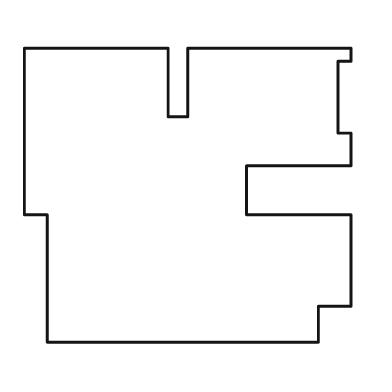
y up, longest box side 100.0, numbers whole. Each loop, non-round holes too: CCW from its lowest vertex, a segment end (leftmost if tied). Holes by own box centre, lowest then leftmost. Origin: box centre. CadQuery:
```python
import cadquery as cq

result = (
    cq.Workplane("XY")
    .moveTo(-43.0, -45.0)
    .lineTo(40.0, -45.0)
    .lineTo(40.0, -34.0)
    .lineTo(50.0, -34.0)
    .lineTo(50.0, -6.0)
    .lineTo(18.0, -6.0)
    .lineTo(18.0, 9.0)
    .lineTo(50.0, 9.0)
    .lineTo(50.0, 19.0)
    .lineTo(46.0, 19.0)
    .lineTo(46.0, 41.0)
    .lineTo(50.0, 41.0)
    .lineTo(50.0, 45.0)
    .lineTo(0.0, 45.0)
    .lineTo(0.0, 24.0)
    .lineTo(-6.0, 24.0)
    .lineTo(-6.0, 45.0)
    .lineTo(-50.0, 45.0)
    .lineTo(-50.0, -6.0)
    .lineTo(-43.0, -6.0)
    .close()
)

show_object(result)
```